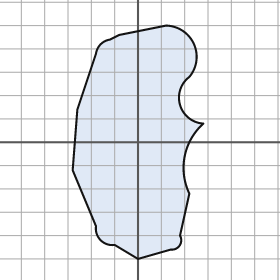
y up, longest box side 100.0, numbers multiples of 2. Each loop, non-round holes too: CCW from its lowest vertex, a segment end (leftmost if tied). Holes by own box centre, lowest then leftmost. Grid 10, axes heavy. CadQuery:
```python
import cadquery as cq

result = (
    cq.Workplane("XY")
    .moveTo(0.0, -50.0)
    .lineTo(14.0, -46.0)
    .threePointArc((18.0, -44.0), (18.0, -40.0))
    .lineTo(22.0, -22.0)
    .threePointArc((20.0, -6.0), (28.0, 8.0))
    .threePointArc((18.0, 16.0), (22.0, 28.0))
    .threePointArc((24.0, 42.0), (12.0, 50.0))
    .lineTo(-8.0, 46.0)
    .lineTo(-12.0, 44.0)
    .threePointArc((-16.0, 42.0), (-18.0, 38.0))
    .lineTo(-26.0, 14.0)
    .lineTo(-28.0, -12.0)
    .lineTo(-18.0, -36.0)
    .threePointArc((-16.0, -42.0), (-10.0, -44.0))
    .close()
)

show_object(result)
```